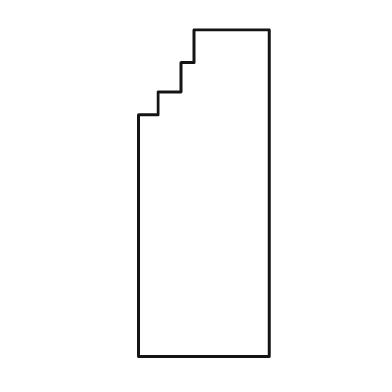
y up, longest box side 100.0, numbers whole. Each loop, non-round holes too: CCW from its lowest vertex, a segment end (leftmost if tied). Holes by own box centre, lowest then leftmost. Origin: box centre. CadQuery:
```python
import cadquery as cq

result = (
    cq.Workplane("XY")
    .moveTo(-20.0, -50.0)
    .lineTo(20.0, -50.0)
    .lineTo(20.0, 50.0)
    .lineTo(-3.0, 50.0)
    .lineTo(-3.0, 40.0)
    .lineTo(-7.0, 40.0)
    .lineTo(-7.0, 31.0)
    .lineTo(-14.0, 31.0)
    .lineTo(-14.0, 24.0)
    .lineTo(-20.0, 24.0)
    .close()
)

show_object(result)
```